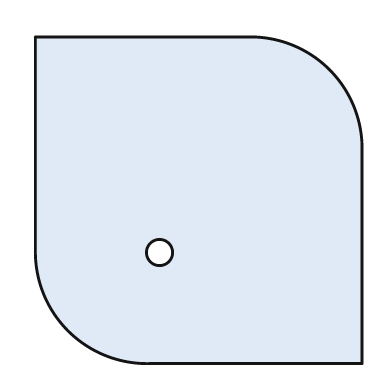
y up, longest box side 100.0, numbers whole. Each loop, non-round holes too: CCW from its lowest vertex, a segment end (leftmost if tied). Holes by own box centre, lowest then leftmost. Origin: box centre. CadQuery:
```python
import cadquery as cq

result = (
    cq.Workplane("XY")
    .moveTo(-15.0, -50.0)
    .lineTo(50.0, -50.0)
    .lineTo(50.0, 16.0)
    .threePointArc((40.0, 40.0), (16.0, 50.0))
    .lineTo(-50.0, 50.0)
    .lineTo(-50.0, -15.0)
    .threePointArc((-40.0, -40.0), (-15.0, -50.0))
    .close()
    .moveTo(-12.0, -16.0)
    .circle(4.0)
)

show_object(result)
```